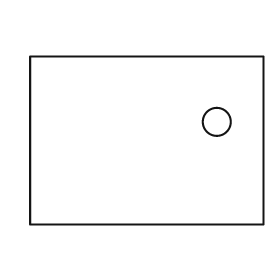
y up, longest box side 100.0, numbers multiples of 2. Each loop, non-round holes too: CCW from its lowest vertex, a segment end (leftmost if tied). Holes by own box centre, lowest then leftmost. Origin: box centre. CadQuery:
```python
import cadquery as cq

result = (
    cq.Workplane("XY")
    .moveTo(-50.0, -36.0)
    .lineTo(50.0, -36.0)
    .lineTo(50.0, 36.0)
    .lineTo(-50.0, 36.0)
    .close()
    .moveTo(30.0, 8.0)
    .circle(6.0)
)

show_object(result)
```